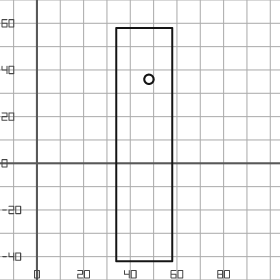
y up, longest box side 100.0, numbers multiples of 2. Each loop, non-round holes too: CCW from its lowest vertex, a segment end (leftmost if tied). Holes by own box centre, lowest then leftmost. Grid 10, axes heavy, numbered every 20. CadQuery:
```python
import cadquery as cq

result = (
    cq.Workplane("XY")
    .moveTo(34.0, -42.0)
    .lineTo(58.0, -42.0)
    .lineTo(58.0, 58.0)
    .lineTo(34.0, 58.0)
    .close()
    .moveTo(48.0, 36.0)
    .circle(2.0)
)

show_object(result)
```